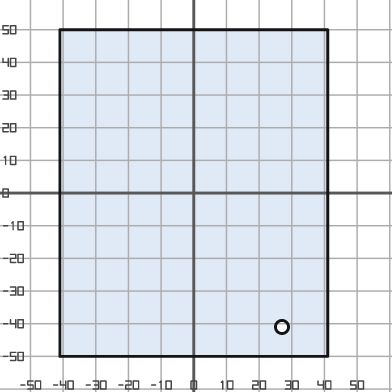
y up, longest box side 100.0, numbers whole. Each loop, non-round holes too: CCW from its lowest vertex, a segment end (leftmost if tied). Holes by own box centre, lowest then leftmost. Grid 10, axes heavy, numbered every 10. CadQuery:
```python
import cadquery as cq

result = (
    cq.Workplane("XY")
    .moveTo(-41.0, -50.0)
    .lineTo(41.0, -50.0)
    .lineTo(41.0, 50.0)
    .lineTo(-41.0, 50.0)
    .close()
    .moveTo(27.0, -41.0)
    .circle(2.0)
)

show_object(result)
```